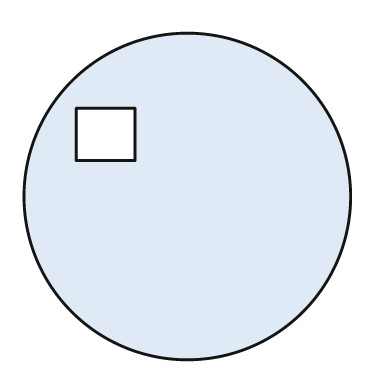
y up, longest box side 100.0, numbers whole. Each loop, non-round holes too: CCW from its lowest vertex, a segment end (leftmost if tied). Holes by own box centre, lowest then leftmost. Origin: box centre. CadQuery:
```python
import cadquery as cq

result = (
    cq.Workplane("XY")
    .moveTo(0.0, 0.0)
    .circle(50.0)
    .moveTo(-34.0, 11.0)
    .lineTo(-16.0, 11.0)
    .lineTo(-16.0, 27.0)
    .lineTo(-34.0, 27.0)
    .close()
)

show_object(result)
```